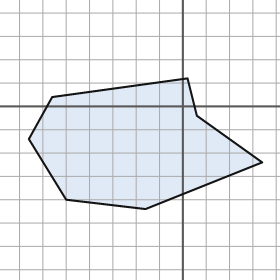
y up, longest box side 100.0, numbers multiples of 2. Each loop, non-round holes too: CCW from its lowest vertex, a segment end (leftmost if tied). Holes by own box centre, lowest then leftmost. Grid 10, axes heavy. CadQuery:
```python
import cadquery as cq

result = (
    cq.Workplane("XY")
    .moveTo(-16.0, -44.0)
    .lineTo(34.0, -24.0)
    .lineTo(6.0, -4.0)
    .lineTo(2.0, 12.0)
    .lineTo(-56.0, 4.0)
    .lineTo(-66.0, -14.0)
    .lineTo(-50.0, -40.0)
    .close()
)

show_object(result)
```